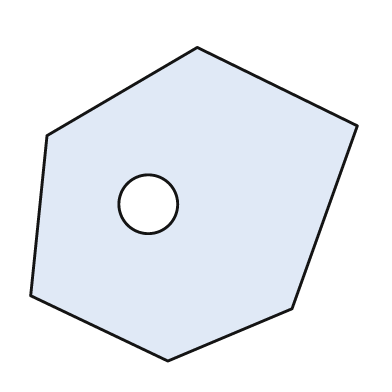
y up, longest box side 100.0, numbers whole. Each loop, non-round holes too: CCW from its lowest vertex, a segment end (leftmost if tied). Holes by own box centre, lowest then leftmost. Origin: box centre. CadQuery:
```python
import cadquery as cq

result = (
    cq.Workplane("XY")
    .moveTo(-8.0, -48.0)
    .lineTo(30.0, -32.0)
    .lineTo(50.0, 24.0)
    .lineTo(1.0, 48.0)
    .lineTo(-45.0, 21.0)
    .lineTo(-50.0, -28.0)
    .close()
    .moveTo(-14.0, 0.0)
    .circle(9.0)
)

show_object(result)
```